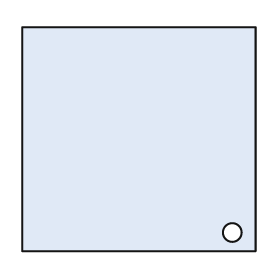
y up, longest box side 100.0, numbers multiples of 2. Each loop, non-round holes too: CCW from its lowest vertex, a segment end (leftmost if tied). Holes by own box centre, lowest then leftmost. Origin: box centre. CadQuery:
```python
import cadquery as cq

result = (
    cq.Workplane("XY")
    .moveTo(-50.0, -48.0)
    .lineTo(50.0, -48.0)
    .lineTo(50.0, 48.0)
    .lineTo(-50.0, 48.0)
    .close()
    .moveTo(40.0, -40.0)
    .circle(4.0)
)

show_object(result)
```